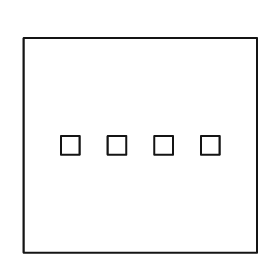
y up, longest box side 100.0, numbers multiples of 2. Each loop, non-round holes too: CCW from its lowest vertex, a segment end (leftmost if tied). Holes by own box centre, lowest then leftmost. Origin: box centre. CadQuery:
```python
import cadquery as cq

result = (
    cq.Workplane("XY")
    .moveTo(-50.0, -46.0)
    .lineTo(50.0, -46.0)
    .lineTo(50.0, 46.0)
    .lineTo(-50.0, 46.0)
    .close()
    .moveTo(-34.0, -4.0)
    .lineTo(-26.0, -4.0)
    .lineTo(-26.0, 4.0)
    .lineTo(-34.0, 4.0)
    .close()
    .moveTo(-14.0, -4.0)
    .lineTo(-6.0, -4.0)
    .lineTo(-6.0, 4.0)
    .lineTo(-14.0, 4.0)
    .close()
    .moveTo(6.0, -4.0)
    .lineTo(14.0, -4.0)
    .lineTo(14.0, 4.0)
    .lineTo(6.0, 4.0)
    .close()
    .moveTo(26.0, -4.0)
    .lineTo(34.0, -4.0)
    .lineTo(34.0, 4.0)
    .lineTo(26.0, 4.0)
    .close()
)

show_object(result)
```